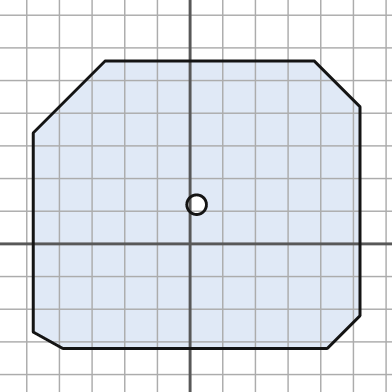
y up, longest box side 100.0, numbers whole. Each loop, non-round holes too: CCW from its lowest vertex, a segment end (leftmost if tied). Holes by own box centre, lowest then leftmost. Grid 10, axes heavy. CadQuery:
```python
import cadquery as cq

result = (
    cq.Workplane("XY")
    .moveTo(-39.0, -32.0)
    .lineTo(42.0, -32.0)
    .lineTo(52.0, -22.0)
    .lineTo(52.0, 42.0)
    .lineTo(38.0, 56.0)
    .lineTo(-26.0, 56.0)
    .lineTo(-48.0, 34.0)
    .lineTo(-48.0, -27.0)
    .close()
    .moveTo(2.0, 12.0)
    .circle(3.0)
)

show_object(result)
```